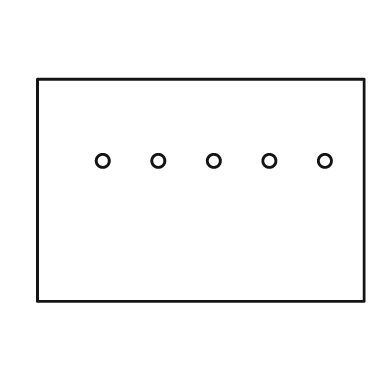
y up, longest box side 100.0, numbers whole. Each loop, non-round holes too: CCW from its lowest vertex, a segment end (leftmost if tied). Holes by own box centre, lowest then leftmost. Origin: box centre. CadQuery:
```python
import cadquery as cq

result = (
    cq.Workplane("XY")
    .moveTo(-50.0, -34.0)
    .lineTo(50.0, -34.0)
    .lineTo(50.0, 34.0)
    .lineTo(-50.0, 34.0)
    .close()
    .moveTo(-30.0, 9.0)
    .circle(2.0)
    .moveTo(-13.0, 9.0)
    .circle(2.0)
    .moveTo(4.0, 9.0)
    .circle(2.0)
    .moveTo(21.0, 9.0)
    .circle(2.0)
    .moveTo(38.0, 9.0)
    .circle(2.0)
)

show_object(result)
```